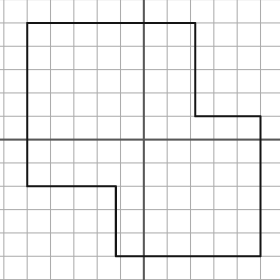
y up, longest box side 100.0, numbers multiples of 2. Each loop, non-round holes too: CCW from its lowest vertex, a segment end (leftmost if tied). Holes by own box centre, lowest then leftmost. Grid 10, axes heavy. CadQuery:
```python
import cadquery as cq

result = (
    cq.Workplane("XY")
    .moveTo(-12.0, -50.0)
    .lineTo(50.0, -50.0)
    .lineTo(50.0, 10.0)
    .lineTo(22.0, 10.0)
    .lineTo(22.0, 50.0)
    .lineTo(-50.0, 50.0)
    .lineTo(-50.0, -20.0)
    .lineTo(-12.0, -20.0)
    .close()
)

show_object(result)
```